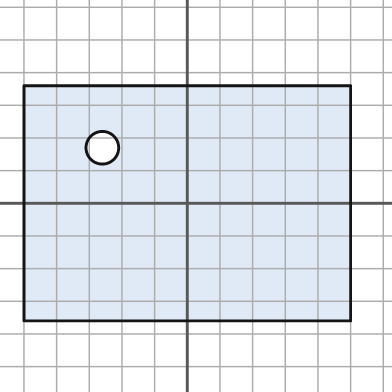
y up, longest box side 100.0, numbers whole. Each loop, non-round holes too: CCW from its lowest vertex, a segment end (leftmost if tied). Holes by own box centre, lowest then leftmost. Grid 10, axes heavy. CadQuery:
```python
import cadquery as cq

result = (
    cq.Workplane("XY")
    .moveTo(-50.0, -36.0)
    .lineTo(50.0, -36.0)
    .lineTo(50.0, 36.0)
    .lineTo(-50.0, 36.0)
    .close()
    .moveTo(-26.0, 17.0)
    .circle(5.0)
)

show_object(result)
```